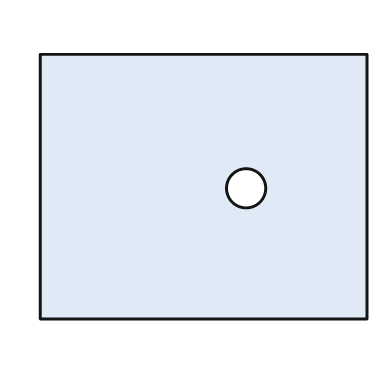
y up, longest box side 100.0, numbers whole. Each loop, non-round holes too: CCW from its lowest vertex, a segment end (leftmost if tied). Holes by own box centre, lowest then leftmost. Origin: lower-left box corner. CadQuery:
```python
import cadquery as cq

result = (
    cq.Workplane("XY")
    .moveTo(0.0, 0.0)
    .lineTo(100.0, 0.0)
    .lineTo(100.0, 81.0)
    .lineTo(0.0, 81.0)
    .close()
    .moveTo(63.0, 40.0)
    .circle(6.0)
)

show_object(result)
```